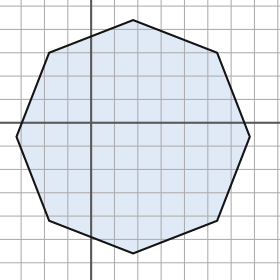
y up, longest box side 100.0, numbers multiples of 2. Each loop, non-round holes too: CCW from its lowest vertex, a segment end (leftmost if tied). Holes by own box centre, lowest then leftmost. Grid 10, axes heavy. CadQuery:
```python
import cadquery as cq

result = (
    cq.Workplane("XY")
    .moveTo(18.0, -56.0)
    .lineTo(54.0, -42.0)
    .lineTo(68.0, -6.0)
    .lineTo(54.0, 30.0)
    .lineTo(18.0, 44.0)
    .lineTo(-18.0, 30.0)
    .lineTo(-32.0, -6.0)
    .lineTo(-18.0, -42.0)
    .close()
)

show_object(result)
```